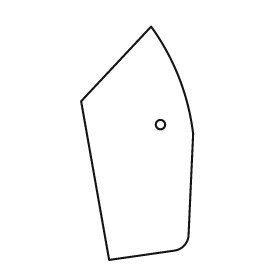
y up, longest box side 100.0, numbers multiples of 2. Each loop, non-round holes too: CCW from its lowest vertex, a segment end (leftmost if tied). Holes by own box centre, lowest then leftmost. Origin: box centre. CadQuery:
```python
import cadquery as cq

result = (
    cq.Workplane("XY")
    .moveTo(-12.0, -50.0)
    .lineTo(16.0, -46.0)
    .threePointArc((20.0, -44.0), (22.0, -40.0))
    .lineTo(24.0, 4.0)
    .threePointArc((18.0, 28.0), (6.0, 50.0))
    .lineTo(-24.0, 18.0)
    .close()
    .moveTo(10.0, 8.0)
    .circle(2.0)
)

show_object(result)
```